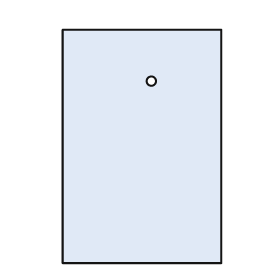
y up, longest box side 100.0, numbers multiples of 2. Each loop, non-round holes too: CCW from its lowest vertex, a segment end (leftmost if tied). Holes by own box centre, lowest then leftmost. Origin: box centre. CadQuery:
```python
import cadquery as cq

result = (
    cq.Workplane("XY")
    .moveTo(-34.0, -50.0)
    .lineTo(34.0, -50.0)
    .lineTo(34.0, 50.0)
    .lineTo(-34.0, 50.0)
    .close()
    .moveTo(4.0, 28.0)
    .circle(2.0)
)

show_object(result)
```